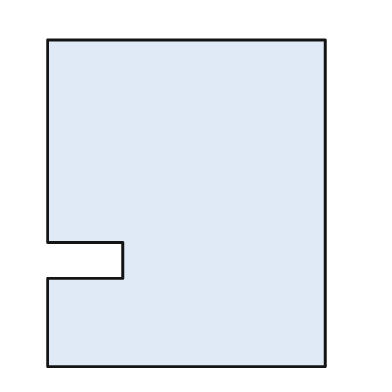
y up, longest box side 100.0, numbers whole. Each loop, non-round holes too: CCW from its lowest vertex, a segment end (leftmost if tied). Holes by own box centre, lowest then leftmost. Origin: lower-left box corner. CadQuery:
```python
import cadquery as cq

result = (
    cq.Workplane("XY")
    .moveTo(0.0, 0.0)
    .lineTo(85.0, 0.0)
    .lineTo(85.0, 100.0)
    .lineTo(0.0, 100.0)
    .lineTo(0.0, 38.0)
    .lineTo(23.0, 38.0)
    .lineTo(23.0, 27.0)
    .lineTo(0.0, 27.0)
    .close()
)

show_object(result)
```